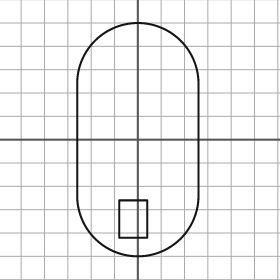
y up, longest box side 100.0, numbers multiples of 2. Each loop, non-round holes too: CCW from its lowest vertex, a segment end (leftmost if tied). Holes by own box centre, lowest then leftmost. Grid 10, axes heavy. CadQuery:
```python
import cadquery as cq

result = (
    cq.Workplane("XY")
    .moveTo(-26.0, -24.0)
    .threePointArc((0.0, -50.0), (26.0, -24.0))
    .lineTo(26.0, 24.0)
    .threePointArc((0.0, 50.0), (-26.0, 24.0))
    .close()
    .moveTo(-8.0, -42.0)
    .lineTo(4.0, -42.0)
    .lineTo(4.0, -26.0)
    .lineTo(-8.0, -26.0)
    .close()
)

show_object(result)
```